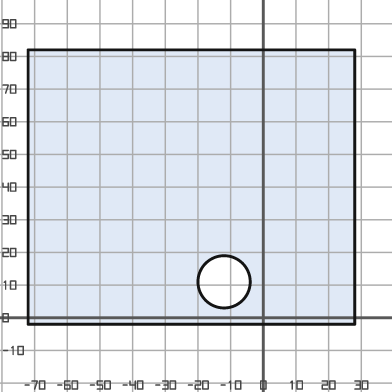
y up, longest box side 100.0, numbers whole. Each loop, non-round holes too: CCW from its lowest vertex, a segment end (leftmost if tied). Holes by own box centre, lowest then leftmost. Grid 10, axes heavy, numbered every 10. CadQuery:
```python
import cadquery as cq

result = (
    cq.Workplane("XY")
    .moveTo(-72.0, -2.0)
    .lineTo(28.0, -2.0)
    .lineTo(28.0, 82.0)
    .lineTo(-72.0, 82.0)
    .close()
    .moveTo(-12.0, 11.0)
    .circle(8.0)
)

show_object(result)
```